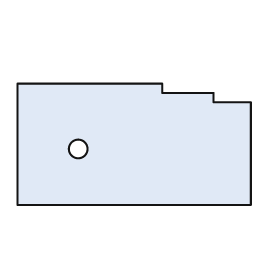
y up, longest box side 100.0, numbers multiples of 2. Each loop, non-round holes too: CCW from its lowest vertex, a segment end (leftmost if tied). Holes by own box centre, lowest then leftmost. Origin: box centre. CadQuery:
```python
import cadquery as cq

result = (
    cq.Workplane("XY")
    .moveTo(-50.0, -26.0)
    .lineTo(50.0, -26.0)
    .lineTo(50.0, 18.0)
    .lineTo(34.0, 18.0)
    .lineTo(34.0, 22.0)
    .lineTo(12.0, 22.0)
    .lineTo(12.0, 26.0)
    .lineTo(-50.0, 26.0)
    .close()
    .moveTo(-24.0, -2.0)
    .circle(4.0)
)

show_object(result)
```